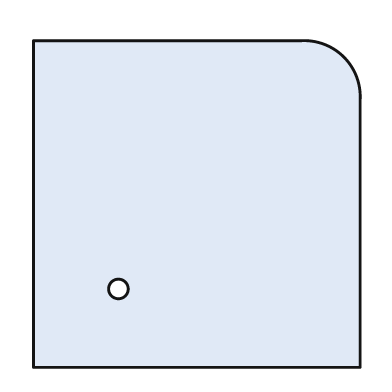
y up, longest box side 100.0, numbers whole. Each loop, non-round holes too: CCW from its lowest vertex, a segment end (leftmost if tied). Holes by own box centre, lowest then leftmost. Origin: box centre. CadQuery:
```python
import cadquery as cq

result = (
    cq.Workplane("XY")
    .moveTo(-50.0, -50.0)
    .lineTo(50.0, -50.0)
    .lineTo(50.0, 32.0)
    .threePointArc((45.0, 45.0), (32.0, 50.0))
    .lineTo(-50.0, 50.0)
    .close()
    .moveTo(-24.0, -26.0)
    .circle(3.0)
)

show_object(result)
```